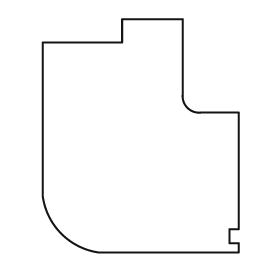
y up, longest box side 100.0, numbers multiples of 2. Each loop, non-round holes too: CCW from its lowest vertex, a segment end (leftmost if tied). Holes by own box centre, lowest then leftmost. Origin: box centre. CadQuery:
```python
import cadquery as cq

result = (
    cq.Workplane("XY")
    .moveTo(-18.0, -50.0)
    .lineTo(42.0, -50.0)
    .lineTo(42.0, -46.0)
    .lineTo(38.0, -46.0)
    .lineTo(38.0, -40.0)
    .lineTo(42.0, -40.0)
    .lineTo(42.0, 10.0)
    .lineTo(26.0, 10.0)
    .threePointArc((20.0, 12.0), (18.0, 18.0))
    .lineTo(18.0, 50.0)
    .lineTo(-8.0, 50.0)
    .lineTo(-8.0, 40.0)
    .lineTo(-42.0, 40.0)
    .lineTo(-42.0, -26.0)
    .threePointArc((-34.0, -42.0), (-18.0, -50.0))
    .close()
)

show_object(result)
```